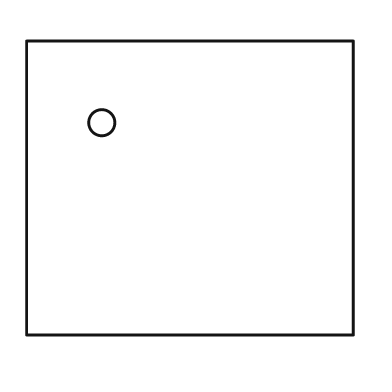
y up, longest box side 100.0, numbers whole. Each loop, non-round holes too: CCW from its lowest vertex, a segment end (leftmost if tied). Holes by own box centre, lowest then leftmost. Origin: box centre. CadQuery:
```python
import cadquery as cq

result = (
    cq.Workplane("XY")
    .moveTo(-50.0, -45.0)
    .lineTo(50.0, -45.0)
    .lineTo(50.0, 45.0)
    .lineTo(-50.0, 45.0)
    .close()
    .moveTo(-27.0, 20.0)
    .circle(4.0)
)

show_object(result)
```